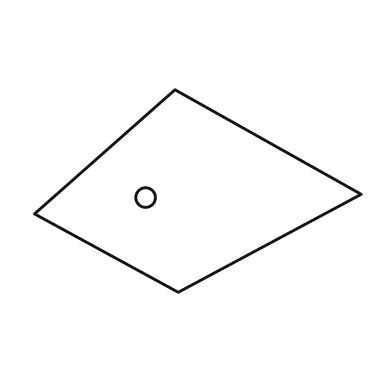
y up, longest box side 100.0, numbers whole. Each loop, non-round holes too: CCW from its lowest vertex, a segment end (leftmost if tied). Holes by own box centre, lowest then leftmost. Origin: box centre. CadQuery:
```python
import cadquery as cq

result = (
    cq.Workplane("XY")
    .moveTo(-6.0, -31.0)
    .lineTo(50.0, -1.0)
    .lineTo(-7.0, 31.0)
    .lineTo(-50.0, -7.0)
    .close()
    .moveTo(-16.0, -2.0)
    .circle(3.0)
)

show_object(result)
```